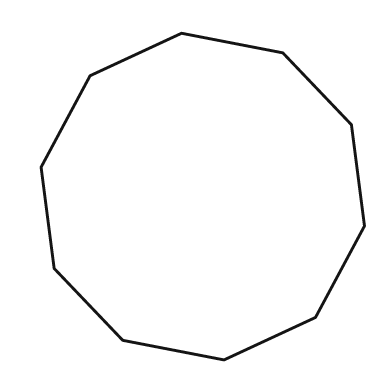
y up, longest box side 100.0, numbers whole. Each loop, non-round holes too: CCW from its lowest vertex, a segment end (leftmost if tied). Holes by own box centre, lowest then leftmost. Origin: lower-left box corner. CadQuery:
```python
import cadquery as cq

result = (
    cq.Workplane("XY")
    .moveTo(56.0, 0.0)
    .lineTo(84.0, 13.0)
    .lineTo(99.0, 41.0)
    .lineTo(95.0, 72.0)
    .lineTo(74.0, 94.0)
    .lineTo(43.0, 100.0)
    .lineTo(15.0, 87.0)
    .lineTo(0.0, 59.0)
    .lineTo(4.0, 28.0)
    .lineTo(25.0, 6.0)
    .close()
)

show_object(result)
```